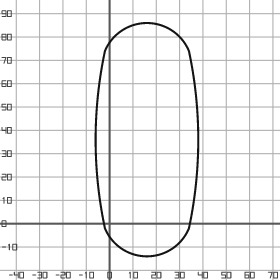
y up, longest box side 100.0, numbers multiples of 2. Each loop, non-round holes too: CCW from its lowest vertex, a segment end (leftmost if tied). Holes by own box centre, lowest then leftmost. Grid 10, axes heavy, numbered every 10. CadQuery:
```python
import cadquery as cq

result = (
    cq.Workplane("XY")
    .moveTo(-2.0, -2.0)
    .threePointArc((16.0, -14.0), (34.0, -2.0))
    .threePointArc((38.0, 36.0), (34.0, 74.0))
    .threePointArc((16.0, 86.0), (-2.0, 74.0))
    .threePointArc((-6.0, 36.0), (-2.0, -2.0))
    .close()
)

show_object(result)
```